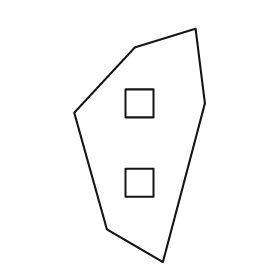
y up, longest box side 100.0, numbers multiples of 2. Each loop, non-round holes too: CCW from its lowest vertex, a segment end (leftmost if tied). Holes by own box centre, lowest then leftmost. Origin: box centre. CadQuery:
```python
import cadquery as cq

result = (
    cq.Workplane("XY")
    .moveTo(10.0, -50.0)
    .lineTo(28.0, 18.0)
    .lineTo(24.0, 50.0)
    .lineTo(-2.0, 42.0)
    .lineTo(-28.0, 14.0)
    .lineTo(-14.0, -36.0)
    .close()
    .moveTo(-6.0, -22.0)
    .lineTo(6.0, -22.0)
    .lineTo(6.0, -10.0)
    .lineTo(-6.0, -10.0)
    .close()
    .moveTo(-6.0, 12.0)
    .lineTo(6.0, 12.0)
    .lineTo(6.0, 24.0)
    .lineTo(-6.0, 24.0)
    .close()
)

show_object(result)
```